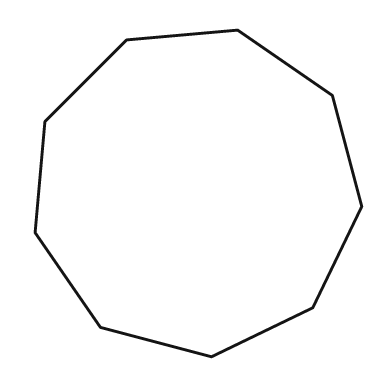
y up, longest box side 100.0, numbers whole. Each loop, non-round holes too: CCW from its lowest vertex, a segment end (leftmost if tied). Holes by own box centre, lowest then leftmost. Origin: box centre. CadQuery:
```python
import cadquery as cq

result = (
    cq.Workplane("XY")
    .moveTo(4.0, -50.0)
    .lineTo(35.0, -35.0)
    .lineTo(50.0, -4.0)
    .lineTo(41.0, 30.0)
    .lineTo(12.0, 50.0)
    .lineTo(-22.0, 47.0)
    .lineTo(-47.0, 22.0)
    .lineTo(-50.0, -12.0)
    .lineTo(-30.0, -41.0)
    .close()
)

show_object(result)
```